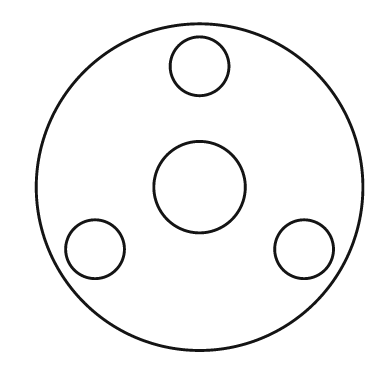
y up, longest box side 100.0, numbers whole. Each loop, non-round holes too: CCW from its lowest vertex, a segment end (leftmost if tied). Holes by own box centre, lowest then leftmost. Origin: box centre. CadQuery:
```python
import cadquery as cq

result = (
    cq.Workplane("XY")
    .moveTo(0.0, 0.0)
    .circle(50.0)
    .moveTo(-32.0, -19.0)
    .circle(9.0)
    .moveTo(32.0, -19.0)
    .circle(9.0)
    .moveTo(0.0, 0.0)
    .circle(14.0)
    .moveTo(0.0, 37.0)
    .circle(9.0)
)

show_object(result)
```